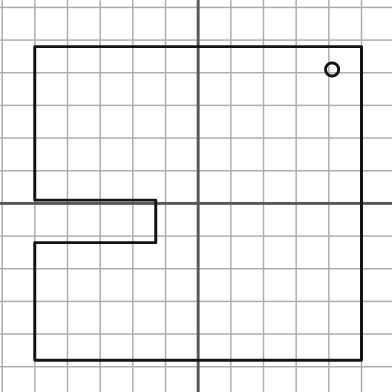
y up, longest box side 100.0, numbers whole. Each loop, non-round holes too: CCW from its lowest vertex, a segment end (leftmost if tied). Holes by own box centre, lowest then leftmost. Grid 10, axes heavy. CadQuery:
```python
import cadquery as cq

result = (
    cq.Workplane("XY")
    .moveTo(-50.0, -48.0)
    .lineTo(50.0, -48.0)
    .lineTo(50.0, 48.0)
    .lineTo(-50.0, 48.0)
    .lineTo(-50.0, 1.0)
    .lineTo(-13.0, 1.0)
    .lineTo(-13.0, -12.0)
    .lineTo(-50.0, -12.0)
    .close()
    .moveTo(41.0, 41.0)
    .circle(2.0)
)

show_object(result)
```